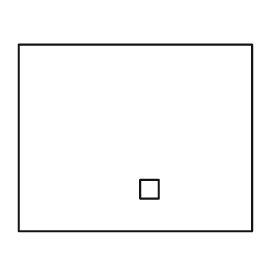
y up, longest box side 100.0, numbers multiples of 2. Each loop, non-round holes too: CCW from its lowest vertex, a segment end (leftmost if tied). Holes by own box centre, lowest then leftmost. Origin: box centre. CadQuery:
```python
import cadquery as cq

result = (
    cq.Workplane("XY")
    .moveTo(-50.0, -40.0)
    .lineTo(50.0, -40.0)
    .lineTo(50.0, 40.0)
    .lineTo(-50.0, 40.0)
    .close()
    .moveTo(2.0, -26.0)
    .lineTo(10.0, -26.0)
    .lineTo(10.0, -18.0)
    .lineTo(2.0, -18.0)
    .close()
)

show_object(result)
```